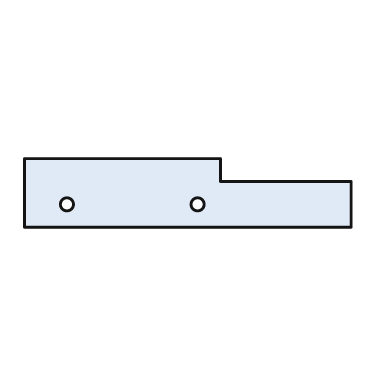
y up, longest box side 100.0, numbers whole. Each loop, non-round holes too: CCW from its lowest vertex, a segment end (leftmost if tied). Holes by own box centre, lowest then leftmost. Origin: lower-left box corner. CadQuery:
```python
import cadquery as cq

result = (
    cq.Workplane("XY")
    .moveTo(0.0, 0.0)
    .lineTo(100.0, 0.0)
    .lineTo(100.0, 14.0)
    .lineTo(60.0, 14.0)
    .lineTo(60.0, 21.0)
    .lineTo(0.0, 21.0)
    .close()
    .moveTo(13.0, 7.0)
    .circle(2.0)
    .moveTo(53.0, 7.0)
    .circle(2.0)
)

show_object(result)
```